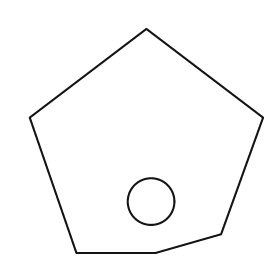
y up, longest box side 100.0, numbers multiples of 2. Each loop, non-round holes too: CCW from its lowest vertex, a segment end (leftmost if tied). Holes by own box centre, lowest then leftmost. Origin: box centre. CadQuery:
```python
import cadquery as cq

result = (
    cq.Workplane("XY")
    .moveTo(-30.0, -48.0)
    .lineTo(4.0, -48.0)
    .lineTo(32.0, -40.0)
    .lineTo(50.0, 10.0)
    .lineTo(0.0, 48.0)
    .lineTo(-50.0, 10.0)
    .close()
    .moveTo(2.0, -26.0)
    .circle(10.0)
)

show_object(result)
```